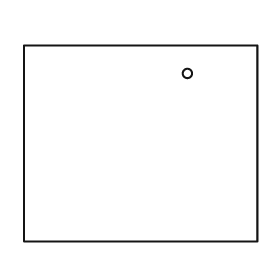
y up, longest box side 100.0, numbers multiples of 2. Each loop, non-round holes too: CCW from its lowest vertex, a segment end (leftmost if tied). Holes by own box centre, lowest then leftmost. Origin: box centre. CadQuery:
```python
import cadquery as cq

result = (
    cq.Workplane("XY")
    .moveTo(-50.0, -42.0)
    .lineTo(50.0, -42.0)
    .lineTo(50.0, 42.0)
    .lineTo(-50.0, 42.0)
    .close()
    .moveTo(20.0, 30.0)
    .circle(2.0)
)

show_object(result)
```